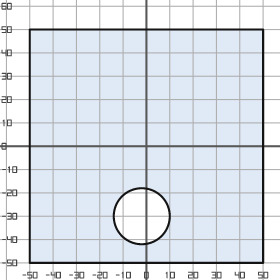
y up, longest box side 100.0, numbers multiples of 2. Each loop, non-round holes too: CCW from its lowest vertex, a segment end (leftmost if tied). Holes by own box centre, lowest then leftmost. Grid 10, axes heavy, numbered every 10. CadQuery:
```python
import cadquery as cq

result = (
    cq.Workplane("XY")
    .moveTo(-50.0, -50.0)
    .lineTo(50.0, -50.0)
    .lineTo(50.0, 50.0)
    .lineTo(-50.0, 50.0)
    .close()
    .moveTo(-2.0, -30.0)
    .circle(12.0)
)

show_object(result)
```